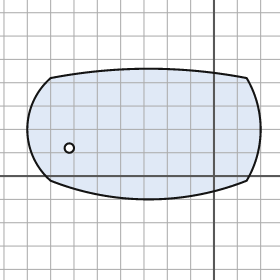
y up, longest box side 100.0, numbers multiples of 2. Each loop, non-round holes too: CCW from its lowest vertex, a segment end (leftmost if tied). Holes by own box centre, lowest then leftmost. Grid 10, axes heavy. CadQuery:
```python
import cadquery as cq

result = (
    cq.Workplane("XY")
    .moveTo(-70.0, -2.0)
    .threePointArc((-28.0, -10.0), (14.0, -2.0))
    .threePointArc((20.0, 20.0), (14.0, 42.0))
    .threePointArc((-28.0, 46.0), (-70.0, 42.0))
    .threePointArc((-80.0, 20.0), (-70.0, -2.0))
    .close()
    .moveTo(-62.0, 12.0)
    .circle(2.0)
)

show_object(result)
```